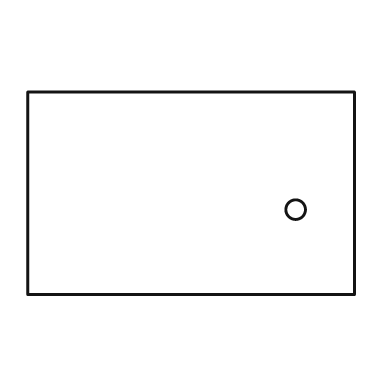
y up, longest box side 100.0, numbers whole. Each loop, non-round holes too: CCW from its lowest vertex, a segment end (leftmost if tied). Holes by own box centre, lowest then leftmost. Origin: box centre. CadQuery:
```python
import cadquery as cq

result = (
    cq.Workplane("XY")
    .moveTo(-50.0, -31.0)
    .lineTo(50.0, -31.0)
    .lineTo(50.0, 31.0)
    .lineTo(-50.0, 31.0)
    .close()
    .moveTo(32.0, -5.0)
    .circle(3.0)
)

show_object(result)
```